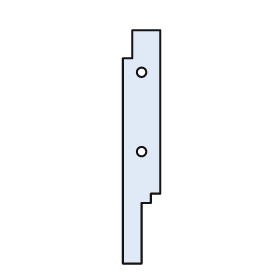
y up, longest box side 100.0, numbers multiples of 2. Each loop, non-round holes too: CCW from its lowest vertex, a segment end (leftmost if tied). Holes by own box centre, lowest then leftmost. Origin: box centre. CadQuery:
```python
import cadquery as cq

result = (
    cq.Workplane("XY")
    .moveTo(-8.0, -50.0)
    .lineTo(0.0, -50.0)
    .lineTo(0.0, -24.0)
    .lineTo(4.0, -24.0)
    .lineTo(4.0, -20.0)
    .lineTo(8.0, -20.0)
    .lineTo(8.0, 50.0)
    .lineTo(-4.0, 50.0)
    .lineTo(-4.0, 38.0)
    .lineTo(-8.0, 38.0)
    .close()
    .moveTo(0.0, -2.0)
    .circle(2.0)
    .moveTo(0.0, 32.0)
    .circle(2.0)
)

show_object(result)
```